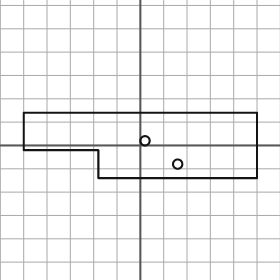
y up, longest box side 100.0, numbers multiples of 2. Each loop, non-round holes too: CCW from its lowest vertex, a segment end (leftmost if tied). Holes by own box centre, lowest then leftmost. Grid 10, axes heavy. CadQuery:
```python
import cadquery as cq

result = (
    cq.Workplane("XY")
    .moveTo(-18.0, -14.0)
    .lineTo(50.0, -14.0)
    .lineTo(50.0, 14.0)
    .lineTo(-50.0, 14.0)
    .lineTo(-50.0, -2.0)
    .lineTo(-18.0, -2.0)
    .close()
    .moveTo(16.0, -8.0)
    .circle(2.0)
    .moveTo(2.0, 2.0)
    .circle(2.0)
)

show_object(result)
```